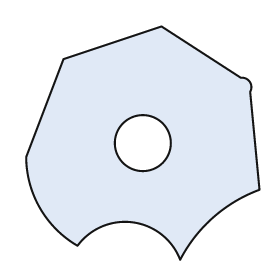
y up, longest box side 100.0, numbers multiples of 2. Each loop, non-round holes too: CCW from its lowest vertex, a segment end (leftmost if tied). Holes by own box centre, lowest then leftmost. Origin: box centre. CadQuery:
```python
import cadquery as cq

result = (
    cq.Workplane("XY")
    .moveTo(16.0, -50.0)
    .threePointArc((30.0, -32.0), (50.0, -20.0))
    .lineTo(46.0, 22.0)
    .threePointArc((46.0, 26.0), (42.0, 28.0))
    .lineTo(8.0, 50.0)
    .lineTo(-34.0, 36.0)
    .lineTo(-50.0, -6.0)
    .threePointArc((-44.0, -28.0), (-28.0, -44.0))
    .threePointArc((-4.0, -34.0), (16.0, -50.0))
    .close()
    .moveTo(0.0, 0.0)
    .circle(12.0)
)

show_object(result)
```